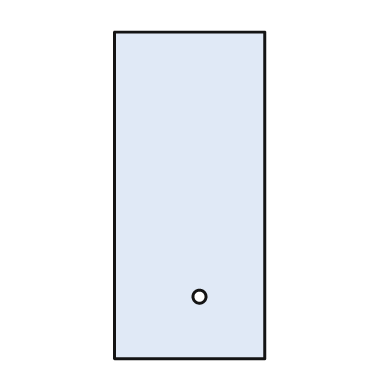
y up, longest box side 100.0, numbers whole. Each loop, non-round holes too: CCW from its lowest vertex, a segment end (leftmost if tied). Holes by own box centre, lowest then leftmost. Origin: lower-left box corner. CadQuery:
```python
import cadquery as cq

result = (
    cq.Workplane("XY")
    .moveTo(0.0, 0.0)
    .lineTo(46.0, 0.0)
    .lineTo(46.0, 100.0)
    .lineTo(0.0, 100.0)
    .close()
    .moveTo(26.0, 19.0)
    .circle(2.0)
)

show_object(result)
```